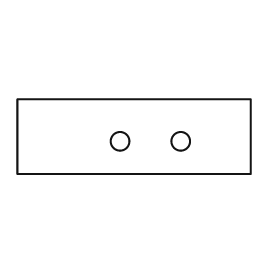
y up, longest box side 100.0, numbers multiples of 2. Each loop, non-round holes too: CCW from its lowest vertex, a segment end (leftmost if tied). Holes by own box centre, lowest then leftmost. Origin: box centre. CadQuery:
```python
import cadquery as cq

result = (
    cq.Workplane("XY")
    .moveTo(-50.0, -16.0)
    .lineTo(50.0, -16.0)
    .lineTo(50.0, 16.0)
    .lineTo(-50.0, 16.0)
    .close()
    .moveTo(-6.0, -2.0)
    .circle(4.0)
    .moveTo(20.0, -2.0)
    .circle(4.0)
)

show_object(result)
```